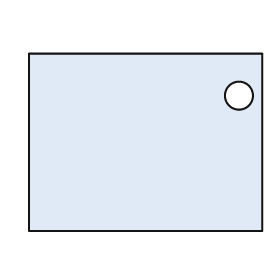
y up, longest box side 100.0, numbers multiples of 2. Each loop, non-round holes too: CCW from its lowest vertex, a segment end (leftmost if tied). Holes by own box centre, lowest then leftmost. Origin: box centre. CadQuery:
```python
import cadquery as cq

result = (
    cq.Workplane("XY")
    .moveTo(-50.0, -38.0)
    .lineTo(50.0, -38.0)
    .lineTo(50.0, 38.0)
    .lineTo(-50.0, 38.0)
    .close()
    .moveTo(40.0, 20.0)
    .circle(6.0)
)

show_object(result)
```